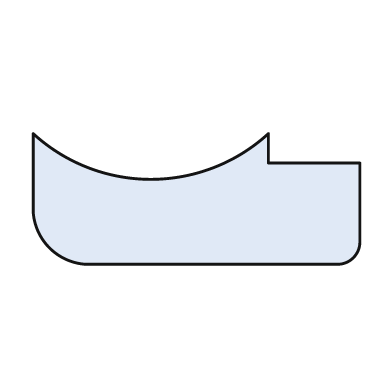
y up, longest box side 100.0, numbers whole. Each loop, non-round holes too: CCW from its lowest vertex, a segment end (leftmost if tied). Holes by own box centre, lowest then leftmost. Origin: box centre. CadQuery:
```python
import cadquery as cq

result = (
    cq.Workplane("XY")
    .moveTo(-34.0, -20.0)
    .lineTo(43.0, -20.0)
    .threePointArc((48.0, -18.0), (50.0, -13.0))
    .lineTo(50.0, 11.0)
    .lineTo(22.0, 11.0)
    .lineTo(22.0, 20.0)
    .threePointArc((-14.0, 6.0), (-50.0, 20.0))
    .lineTo(-50.0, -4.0)
    .threePointArc((-45.0, -15.0), (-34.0, -20.0))
    .close()
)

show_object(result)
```